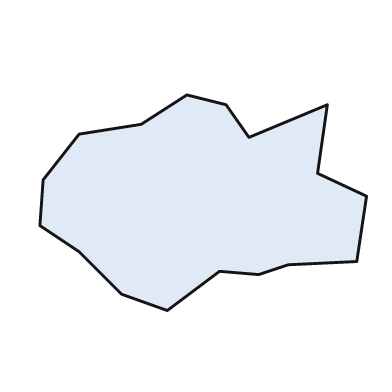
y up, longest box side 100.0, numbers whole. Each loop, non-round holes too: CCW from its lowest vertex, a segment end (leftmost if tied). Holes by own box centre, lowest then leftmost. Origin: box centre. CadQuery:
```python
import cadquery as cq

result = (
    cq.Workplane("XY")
    .moveTo(-11.0, -33.0)
    .lineTo(5.0, -21.0)
    .lineTo(17.0, -22.0)
    .lineTo(26.0, -19.0)
    .lineTo(47.0, -18.0)
    .lineTo(50.0, 2.0)
    .lineTo(35.0, 9.0)
    .lineTo(38.0, 30.0)
    .lineTo(14.0, 20.0)
    .lineTo(7.0, 30.0)
    .lineTo(-5.0, 33.0)
    .lineTo(-19.0, 24.0)
    .lineTo(-38.0, 21.0)
    .lineTo(-49.0, 7.0)
    .lineTo(-50.0, -7.0)
    .lineTo(-38.0, -15.0)
    .lineTo(-25.0, -28.0)
    .close()
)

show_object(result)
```